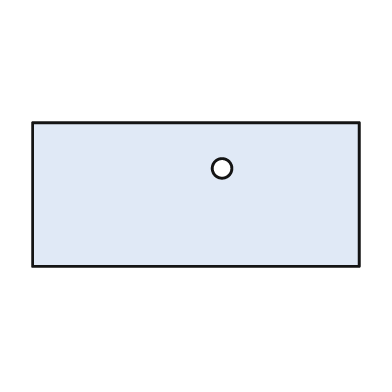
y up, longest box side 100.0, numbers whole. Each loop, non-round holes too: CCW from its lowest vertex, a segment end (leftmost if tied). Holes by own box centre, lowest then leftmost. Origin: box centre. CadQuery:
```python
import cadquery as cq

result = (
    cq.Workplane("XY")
    .moveTo(-50.0, -22.0)
    .lineTo(50.0, -22.0)
    .lineTo(50.0, 22.0)
    .lineTo(-50.0, 22.0)
    .close()
    .moveTo(8.0, 8.0)
    .circle(3.0)
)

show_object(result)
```